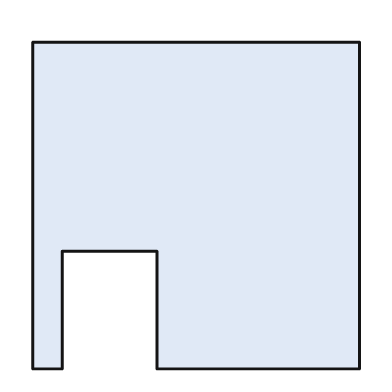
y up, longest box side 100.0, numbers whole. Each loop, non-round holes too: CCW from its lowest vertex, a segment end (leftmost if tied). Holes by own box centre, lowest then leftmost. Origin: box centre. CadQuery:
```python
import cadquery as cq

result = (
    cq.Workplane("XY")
    .moveTo(-50.0, -50.0)
    .lineTo(-41.0, -50.0)
    .lineTo(-41.0, -14.0)
    .lineTo(-12.0, -14.0)
    .lineTo(-12.0, -50.0)
    .lineTo(50.0, -50.0)
    .lineTo(50.0, 50.0)
    .lineTo(-50.0, 50.0)
    .close()
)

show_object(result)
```